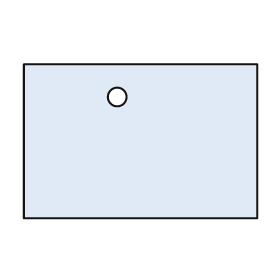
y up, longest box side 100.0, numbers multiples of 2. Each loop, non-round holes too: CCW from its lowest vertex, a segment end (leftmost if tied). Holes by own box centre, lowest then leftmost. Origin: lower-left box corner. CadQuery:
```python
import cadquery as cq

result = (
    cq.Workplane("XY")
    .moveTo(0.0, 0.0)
    .lineTo(100.0, 0.0)
    .lineTo(100.0, 66.0)
    .lineTo(0.0, 66.0)
    .close()
    .moveTo(40.0, 52.0)
    .circle(4.0)
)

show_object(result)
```